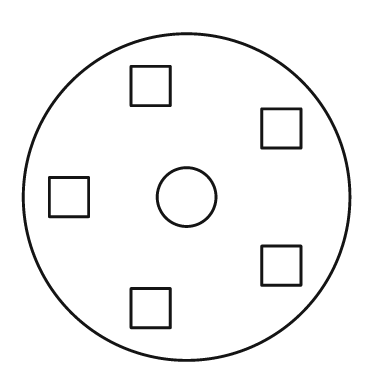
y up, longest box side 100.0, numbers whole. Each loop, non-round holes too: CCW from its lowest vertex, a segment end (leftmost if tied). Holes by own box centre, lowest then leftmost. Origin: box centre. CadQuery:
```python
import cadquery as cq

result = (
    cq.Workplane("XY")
    .moveTo(0.0, 0.0)
    .circle(50.0)
    .moveTo(-17.0, -40.0)
    .lineTo(-5.0, -40.0)
    .lineTo(-5.0, -28.0)
    .lineTo(-17.0, -28.0)
    .close()
    .moveTo(23.0, -27.0)
    .lineTo(35.0, -27.0)
    .lineTo(35.0, -15.0)
    .lineTo(23.0, -15.0)
    .close()
    .moveTo(-42.0, -6.0)
    .lineTo(-30.0, -6.0)
    .lineTo(-30.0, 6.0)
    .lineTo(-42.0, 6.0)
    .close()
    .moveTo(0.0, 0.0)
    .circle(9.0)
    .moveTo(23.0, 15.0)
    .lineTo(35.0, 15.0)
    .lineTo(35.0, 27.0)
    .lineTo(23.0, 27.0)
    .close()
    .moveTo(-17.0, 28.0)
    .lineTo(-5.0, 28.0)
    .lineTo(-5.0, 40.0)
    .lineTo(-17.0, 40.0)
    .close()
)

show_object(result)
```